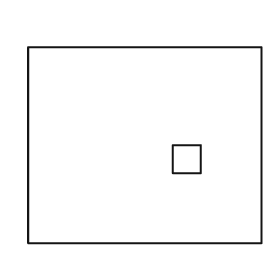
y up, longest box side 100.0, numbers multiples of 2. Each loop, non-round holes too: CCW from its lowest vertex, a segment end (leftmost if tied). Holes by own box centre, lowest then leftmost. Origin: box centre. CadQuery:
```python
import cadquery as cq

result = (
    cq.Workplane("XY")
    .moveTo(-50.0, -42.0)
    .lineTo(50.0, -42.0)
    .lineTo(50.0, 42.0)
    .lineTo(-50.0, 42.0)
    .close()
    .moveTo(12.0, -12.0)
    .lineTo(24.0, -12.0)
    .lineTo(24.0, 0.0)
    .lineTo(12.0, 0.0)
    .close()
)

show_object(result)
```